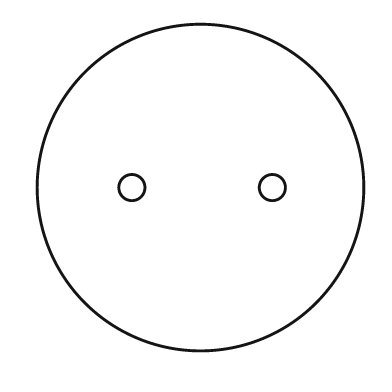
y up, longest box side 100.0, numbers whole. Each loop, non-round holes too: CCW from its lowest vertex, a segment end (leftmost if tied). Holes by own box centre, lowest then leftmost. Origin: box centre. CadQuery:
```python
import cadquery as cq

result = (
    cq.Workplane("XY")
    .moveTo(0.0, 0.0)
    .circle(50.0)
    .moveTo(-21.0, 0.0)
    .circle(4.0)
    .moveTo(22.0, 0.0)
    .circle(4.0)
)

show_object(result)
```